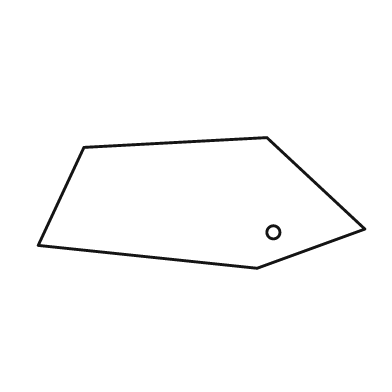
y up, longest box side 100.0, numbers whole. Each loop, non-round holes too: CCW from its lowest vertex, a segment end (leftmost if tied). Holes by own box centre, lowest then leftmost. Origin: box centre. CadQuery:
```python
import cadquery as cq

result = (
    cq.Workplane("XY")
    .moveTo(17.0, -20.0)
    .lineTo(50.0, -8.0)
    .lineTo(20.0, 20.0)
    .lineTo(-36.0, 17.0)
    .lineTo(-50.0, -13.0)
    .close()
    .moveTo(22.0, -9.0)
    .circle(2.0)
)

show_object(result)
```